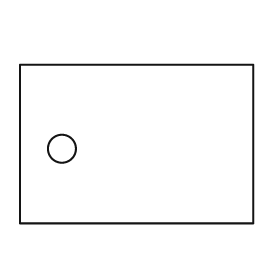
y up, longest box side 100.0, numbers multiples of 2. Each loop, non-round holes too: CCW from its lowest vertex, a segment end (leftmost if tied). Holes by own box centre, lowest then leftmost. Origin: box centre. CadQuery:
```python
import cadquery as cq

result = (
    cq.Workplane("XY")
    .moveTo(-50.0, -34.0)
    .lineTo(50.0, -34.0)
    .lineTo(50.0, 34.0)
    .lineTo(-50.0, 34.0)
    .close()
    .moveTo(-32.0, -2.0)
    .circle(6.0)
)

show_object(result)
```